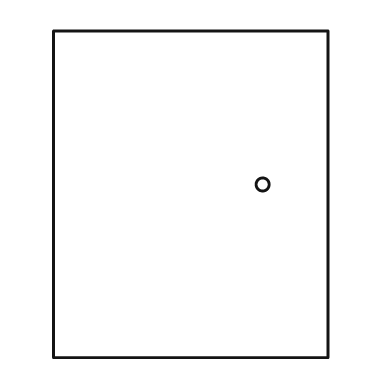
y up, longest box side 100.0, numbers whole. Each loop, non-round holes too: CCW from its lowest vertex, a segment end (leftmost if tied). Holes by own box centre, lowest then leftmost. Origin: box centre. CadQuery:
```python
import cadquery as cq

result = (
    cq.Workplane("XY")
    .moveTo(-42.0, -50.0)
    .lineTo(42.0, -50.0)
    .lineTo(42.0, 50.0)
    .lineTo(-42.0, 50.0)
    .close()
    .moveTo(22.0, 3.0)
    .circle(2.0)
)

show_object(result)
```